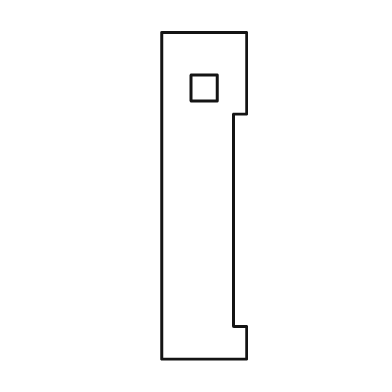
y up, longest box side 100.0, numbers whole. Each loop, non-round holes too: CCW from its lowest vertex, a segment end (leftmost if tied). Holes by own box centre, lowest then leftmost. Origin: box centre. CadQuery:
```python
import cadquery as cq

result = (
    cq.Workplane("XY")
    .moveTo(-13.0, -50.0)
    .lineTo(13.0, -50.0)
    .lineTo(13.0, -40.0)
    .lineTo(9.0, -40.0)
    .lineTo(9.0, 25.0)
    .lineTo(13.0, 25.0)
    .lineTo(13.0, 50.0)
    .lineTo(-13.0, 50.0)
    .close()
    .moveTo(-4.0, 29.0)
    .lineTo(4.0, 29.0)
    .lineTo(4.0, 37.0)
    .lineTo(-4.0, 37.0)
    .close()
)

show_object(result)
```